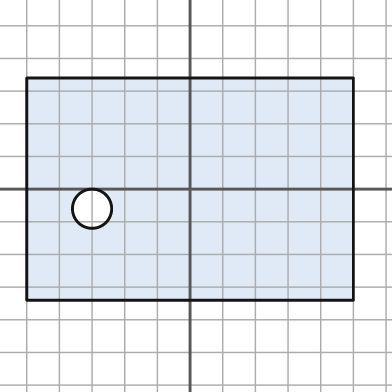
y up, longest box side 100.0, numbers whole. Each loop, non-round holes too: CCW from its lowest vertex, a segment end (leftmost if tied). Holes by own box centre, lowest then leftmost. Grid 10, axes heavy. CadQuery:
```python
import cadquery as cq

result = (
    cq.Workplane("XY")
    .moveTo(-50.0, -34.0)
    .lineTo(50.0, -34.0)
    .lineTo(50.0, 34.0)
    .lineTo(-50.0, 34.0)
    .close()
    .moveTo(-30.0, -6.0)
    .circle(6.0)
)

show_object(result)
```